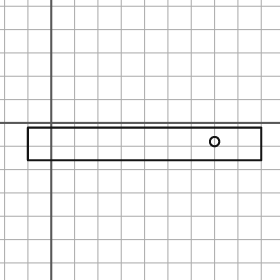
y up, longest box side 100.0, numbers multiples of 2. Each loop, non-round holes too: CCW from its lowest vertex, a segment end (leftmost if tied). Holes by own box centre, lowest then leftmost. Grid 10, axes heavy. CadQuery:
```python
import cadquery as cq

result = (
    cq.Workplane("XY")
    .moveTo(-10.0, -16.0)
    .lineTo(90.0, -16.0)
    .lineTo(90.0, -2.0)
    .lineTo(-10.0, -2.0)
    .close()
    .moveTo(70.0, -8.0)
    .circle(2.0)
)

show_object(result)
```